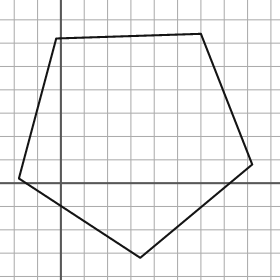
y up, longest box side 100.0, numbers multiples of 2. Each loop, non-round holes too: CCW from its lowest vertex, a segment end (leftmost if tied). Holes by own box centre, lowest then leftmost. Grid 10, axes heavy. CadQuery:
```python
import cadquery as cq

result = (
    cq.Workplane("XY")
    .moveTo(34.0, -32.0)
    .lineTo(82.0, 8.0)
    .lineTo(60.0, 64.0)
    .lineTo(-2.0, 62.0)
    .lineTo(-18.0, 2.0)
    .close()
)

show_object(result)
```